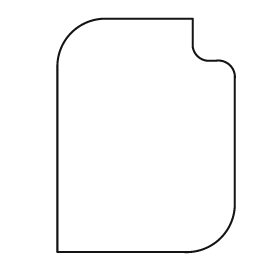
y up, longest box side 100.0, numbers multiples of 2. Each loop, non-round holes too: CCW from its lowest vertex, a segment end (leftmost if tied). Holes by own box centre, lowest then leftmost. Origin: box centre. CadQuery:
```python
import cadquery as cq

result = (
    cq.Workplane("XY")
    .moveTo(-38.0, -50.0)
    .lineTo(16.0, -50.0)
    .threePointArc((32.0, -44.0), (38.0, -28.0))
    .lineTo(38.0, 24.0)
    .threePointArc((36.0, 30.0), (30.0, 32.0))
    .lineTo(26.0, 32.0)
    .threePointArc((22.0, 34.0), (20.0, 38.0))
    .lineTo(20.0, 50.0)
    .lineTo(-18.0, 50.0)
    .threePointArc((-32.0, 44.0), (-38.0, 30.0))
    .close()
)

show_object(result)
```